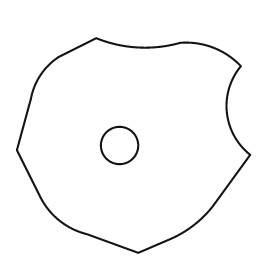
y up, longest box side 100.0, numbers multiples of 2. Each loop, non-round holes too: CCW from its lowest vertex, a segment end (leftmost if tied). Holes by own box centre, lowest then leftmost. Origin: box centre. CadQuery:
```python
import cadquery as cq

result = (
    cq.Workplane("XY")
    .moveTo(2.0, -46.0)
    .lineTo(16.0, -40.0)
    .threePointArc((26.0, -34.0), (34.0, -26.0))
    .lineTo(50.0, -4.0)
    .threePointArc((40.0, 14.0), (46.0, 34.0))
    .threePointArc((34.0, 42.0), (20.0, 44.0))
    .threePointArc((2.0, 42.0), (-16.0, 46.0))
    .lineTo(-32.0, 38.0)
    .threePointArc((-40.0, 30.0), (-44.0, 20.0))
    .lineTo(-50.0, -2.0)
    .lineTo(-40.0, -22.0)
    .threePointArc((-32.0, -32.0), (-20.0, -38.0))
    .close()
    .moveTo(-6.0, 0.0)
    .circle(8.0)
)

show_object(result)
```